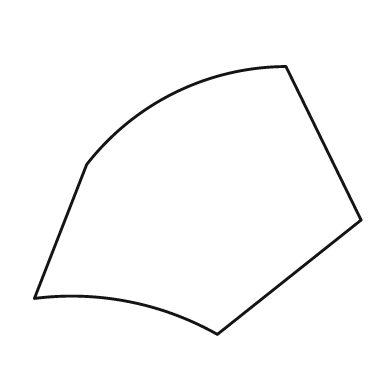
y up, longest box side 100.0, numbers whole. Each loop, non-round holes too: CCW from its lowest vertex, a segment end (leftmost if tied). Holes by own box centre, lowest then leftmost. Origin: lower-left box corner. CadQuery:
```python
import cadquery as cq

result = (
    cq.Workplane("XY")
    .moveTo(56.0, 0.0)
    .lineTo(100.0, 35.0)
    .lineTo(77.0, 82.0)
    .threePointArc((43.0, 74.0), (16.0, 52.0))
    .lineTo(0.0, 11.0)
    .threePointArc((29.0, 10.0), (56.0, 0.0))
    .close()
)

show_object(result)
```